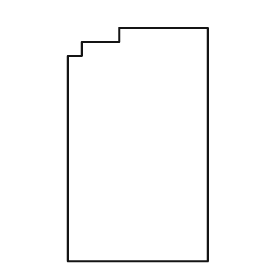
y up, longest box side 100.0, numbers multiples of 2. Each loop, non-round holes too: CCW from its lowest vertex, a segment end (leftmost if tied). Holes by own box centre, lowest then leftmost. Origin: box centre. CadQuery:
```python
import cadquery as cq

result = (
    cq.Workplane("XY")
    .moveTo(-30.0, -50.0)
    .lineTo(30.0, -50.0)
    .lineTo(30.0, 50.0)
    .lineTo(-8.0, 50.0)
    .lineTo(-8.0, 44.0)
    .lineTo(-24.0, 44.0)
    .lineTo(-24.0, 38.0)
    .lineTo(-30.0, 38.0)
    .close()
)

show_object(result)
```